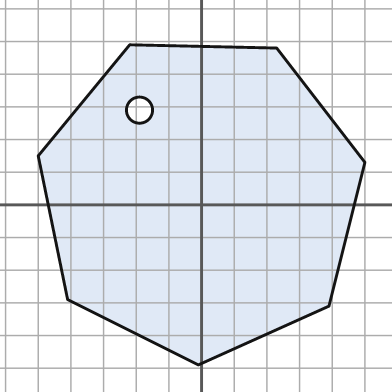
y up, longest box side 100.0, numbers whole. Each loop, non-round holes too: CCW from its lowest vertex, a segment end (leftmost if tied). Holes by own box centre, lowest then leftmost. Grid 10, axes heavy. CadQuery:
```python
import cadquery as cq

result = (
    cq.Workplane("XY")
    .moveTo(-1.0, -49.0)
    .lineTo(39.0, -31.0)
    .lineTo(50.0, 13.0)
    .lineTo(23.0, 48.0)
    .lineTo(-22.0, 49.0)
    .lineTo(-50.0, 15.0)
    .lineTo(-41.0, -29.0)
    .close()
    .moveTo(-19.0, 29.0)
    .circle(4.0)
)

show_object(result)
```